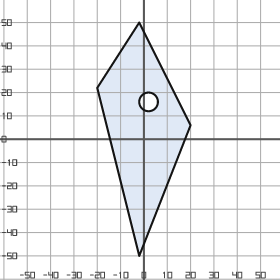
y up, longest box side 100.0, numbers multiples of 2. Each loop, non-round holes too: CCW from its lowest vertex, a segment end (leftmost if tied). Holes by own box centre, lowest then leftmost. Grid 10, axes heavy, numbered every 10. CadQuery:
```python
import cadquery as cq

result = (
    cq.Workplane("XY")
    .moveTo(-2.0, -50.0)
    .lineTo(20.0, 6.0)
    .lineTo(-2.0, 50.0)
    .lineTo(-20.0, 22.0)
    .close()
    .moveTo(2.0, 16.0)
    .circle(4.0)
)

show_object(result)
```